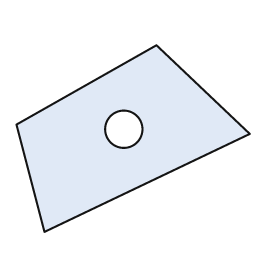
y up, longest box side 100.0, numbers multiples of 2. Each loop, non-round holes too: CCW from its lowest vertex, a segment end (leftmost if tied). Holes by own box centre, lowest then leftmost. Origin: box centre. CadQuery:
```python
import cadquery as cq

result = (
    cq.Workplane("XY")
    .moveTo(-38.0, -40.0)
    .lineTo(50.0, 2.0)
    .lineTo(10.0, 40.0)
    .lineTo(-50.0, 6.0)
    .close()
    .moveTo(-4.0, 4.0)
    .circle(8.0)
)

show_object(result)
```